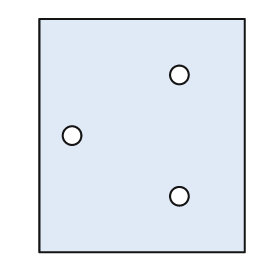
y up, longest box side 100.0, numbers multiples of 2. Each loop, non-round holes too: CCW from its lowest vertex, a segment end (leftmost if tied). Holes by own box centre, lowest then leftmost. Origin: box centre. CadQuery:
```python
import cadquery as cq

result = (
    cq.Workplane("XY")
    .moveTo(-44.0, -50.0)
    .lineTo(44.0, -50.0)
    .lineTo(44.0, 50.0)
    .lineTo(-44.0, 50.0)
    .close()
    .moveTo(16.0, -26.0)
    .circle(4.0)
    .moveTo(-30.0, 0.0)
    .circle(4.0)
    .moveTo(16.0, 26.0)
    .circle(4.0)
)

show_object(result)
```